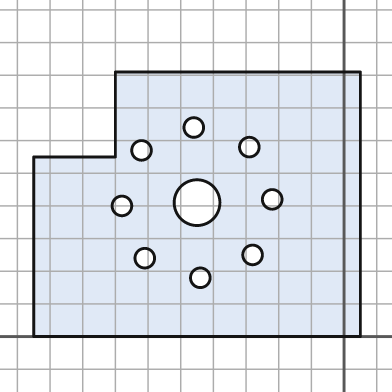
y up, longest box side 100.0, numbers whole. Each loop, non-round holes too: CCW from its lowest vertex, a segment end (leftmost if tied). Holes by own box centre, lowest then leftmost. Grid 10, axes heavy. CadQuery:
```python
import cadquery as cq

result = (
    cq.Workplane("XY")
    .moveTo(-95.0, 0.0)
    .lineTo(5.0, 0.0)
    .lineTo(5.0, 81.0)
    .lineTo(-70.0, 81.0)
    .lineTo(-70.0, 55.0)
    .lineTo(-95.0, 55.0)
    .close()
    .moveTo(-44.0, 18.0)
    .circle(3.0)
    .moveTo(-61.0, 24.0)
    .circle(3.0)
    .moveTo(-28.0, 25.0)
    .circle(3.0)
    .moveTo(-68.0, 40.0)
    .circle(3.0)
    .moveTo(-45.0, 41.0)
    .circle(7.0)
    .moveTo(-22.0, 42.0)
    .circle(3.0)
    .moveTo(-62.0, 57.0)
    .circle(3.0)
    .moveTo(-29.0, 58.0)
    .circle(3.0)
    .moveTo(-46.0, 64.0)
    .circle(3.0)
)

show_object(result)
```